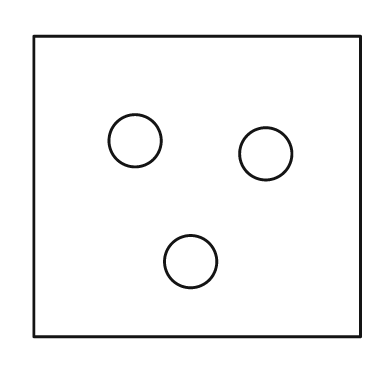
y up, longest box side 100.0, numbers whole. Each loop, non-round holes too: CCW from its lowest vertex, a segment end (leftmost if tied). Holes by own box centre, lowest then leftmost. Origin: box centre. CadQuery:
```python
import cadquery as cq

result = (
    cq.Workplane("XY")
    .moveTo(-50.0, -46.0)
    .lineTo(50.0, -46.0)
    .lineTo(50.0, 46.0)
    .lineTo(-50.0, 46.0)
    .close()
    .moveTo(-2.0, -23.0)
    .circle(8.0)
    .moveTo(21.0, 10.0)
    .circle(8.0)
    .moveTo(-19.0, 14.0)
    .circle(8.0)
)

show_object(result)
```